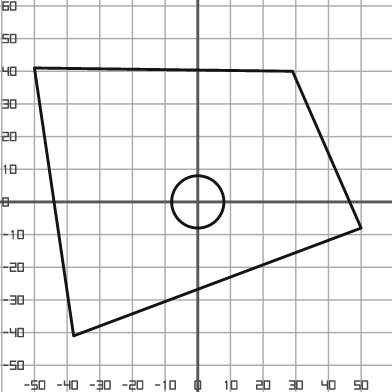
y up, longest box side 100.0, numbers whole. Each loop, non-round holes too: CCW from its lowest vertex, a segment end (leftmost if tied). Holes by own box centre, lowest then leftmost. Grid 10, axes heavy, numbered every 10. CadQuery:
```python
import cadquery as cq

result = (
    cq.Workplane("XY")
    .moveTo(-38.0, -41.0)
    .lineTo(50.0, -8.0)
    .lineTo(29.0, 40.0)
    .lineTo(-50.0, 41.0)
    .close()
    .moveTo(0.0, 0.0)
    .circle(8.0)
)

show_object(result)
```